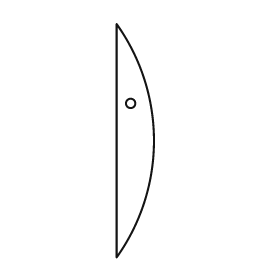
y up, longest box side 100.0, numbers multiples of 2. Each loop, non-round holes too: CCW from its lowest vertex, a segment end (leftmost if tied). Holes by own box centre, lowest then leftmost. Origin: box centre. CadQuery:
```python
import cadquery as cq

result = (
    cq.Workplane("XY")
    .moveTo(-8.0, -50.0)
    .threePointArc((8.0, 0.0), (-8.0, 50.0))
    .close()
    .moveTo(-2.0, 16.0)
    .circle(2.0)
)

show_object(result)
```